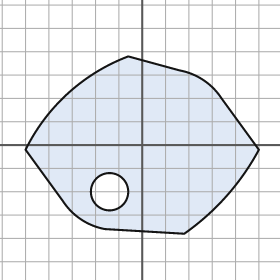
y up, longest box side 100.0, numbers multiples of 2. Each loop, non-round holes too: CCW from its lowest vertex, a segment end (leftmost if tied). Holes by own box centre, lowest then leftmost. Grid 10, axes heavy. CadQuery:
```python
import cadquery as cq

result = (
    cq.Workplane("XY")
    .moveTo(18.0, -38.0)
    .threePointArc((36.0, -22.0), (50.0, -2.0))
    .lineTo(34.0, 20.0)
    .threePointArc((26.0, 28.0), (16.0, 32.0))
    .lineTo(-6.0, 38.0)
    .threePointArc((-32.0, 22.0), (-50.0, -2.0))
    .lineTo(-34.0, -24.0)
    .threePointArc((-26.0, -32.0), (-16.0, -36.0))
    .close()
    .moveTo(-14.0, -20.0)
    .circle(8.0)
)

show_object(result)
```